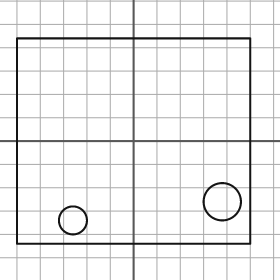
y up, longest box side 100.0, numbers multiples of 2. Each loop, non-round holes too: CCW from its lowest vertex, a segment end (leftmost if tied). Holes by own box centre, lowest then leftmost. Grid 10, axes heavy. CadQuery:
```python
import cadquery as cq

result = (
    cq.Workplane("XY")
    .moveTo(-50.0, -44.0)
    .lineTo(50.0, -44.0)
    .lineTo(50.0, 44.0)
    .lineTo(-50.0, 44.0)
    .close()
    .moveTo(-26.0, -34.0)
    .circle(6.0)
    .moveTo(38.0, -26.0)
    .circle(8.0)
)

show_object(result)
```